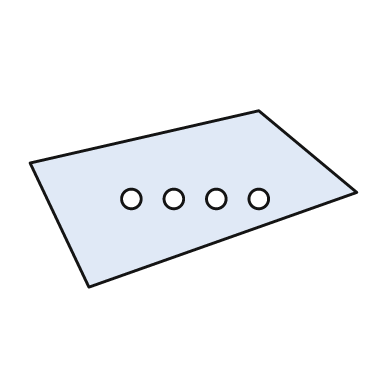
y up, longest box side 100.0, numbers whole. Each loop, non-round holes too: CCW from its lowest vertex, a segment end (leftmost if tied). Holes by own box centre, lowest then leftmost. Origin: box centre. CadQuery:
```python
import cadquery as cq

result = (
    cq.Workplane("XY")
    .moveTo(-32.0, -27.0)
    .lineTo(50.0, 2.0)
    .lineTo(20.0, 27.0)
    .lineTo(-50.0, 11.0)
    .close()
    .moveTo(-19.0, 0.0)
    .circle(3.0)
    .moveTo(-6.0, 0.0)
    .circle(3.0)
    .moveTo(7.0, 0.0)
    .circle(3.0)
    .moveTo(20.0, 0.0)
    .circle(3.0)
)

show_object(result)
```